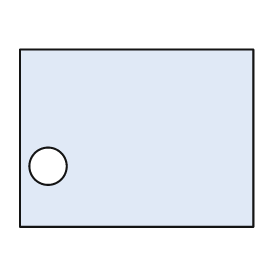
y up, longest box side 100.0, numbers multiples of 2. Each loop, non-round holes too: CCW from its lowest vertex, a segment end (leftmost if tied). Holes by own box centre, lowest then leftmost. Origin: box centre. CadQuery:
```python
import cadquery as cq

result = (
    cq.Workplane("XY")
    .moveTo(-50.0, -38.0)
    .lineTo(50.0, -38.0)
    .lineTo(50.0, 38.0)
    .lineTo(-50.0, 38.0)
    .close()
    .moveTo(-38.0, -12.0)
    .circle(8.0)
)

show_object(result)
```